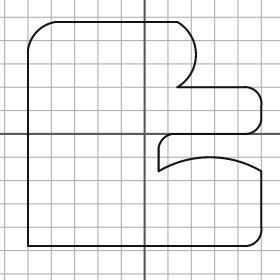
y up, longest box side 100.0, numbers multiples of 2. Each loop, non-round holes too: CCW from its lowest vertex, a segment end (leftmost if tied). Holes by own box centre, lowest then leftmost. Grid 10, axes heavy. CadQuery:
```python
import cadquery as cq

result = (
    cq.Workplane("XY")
    .moveTo(-50.0, -48.0)
    .lineTo(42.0, -48.0)
    .threePointArc((48.0, -46.0), (50.0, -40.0))
    .lineTo(50.0, -16.0)
    .threePointArc((28.0, -10.0), (6.0, -16.0))
    .lineTo(6.0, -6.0)
    .threePointArc((8.0, -2.0), (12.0, 0.0))
    .lineTo(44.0, 0.0)
    .threePointArc((48.0, 2.0), (50.0, 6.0))
    .lineTo(50.0, 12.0)
    .threePointArc((48.0, 18.0), (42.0, 20.0))
    .lineTo(14.0, 20.0)
    .threePointArc((22.0, 34.0), (14.0, 48.0))
    .lineTo(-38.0, 48.0)
    .threePointArc((-46.0, 44.0), (-50.0, 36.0))
    .close()
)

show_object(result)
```